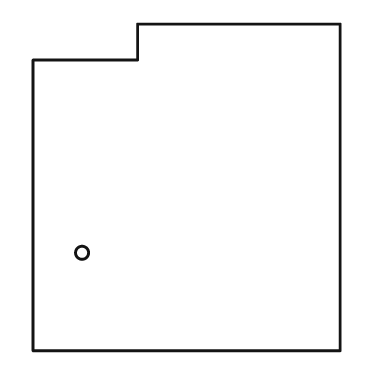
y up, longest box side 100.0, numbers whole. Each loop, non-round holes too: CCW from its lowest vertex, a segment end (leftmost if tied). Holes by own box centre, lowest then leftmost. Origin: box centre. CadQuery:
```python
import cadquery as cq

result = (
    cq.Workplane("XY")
    .moveTo(-47.0, -50.0)
    .lineTo(47.0, -50.0)
    .lineTo(47.0, 50.0)
    .lineTo(-15.0, 50.0)
    .lineTo(-15.0, 39.0)
    .lineTo(-47.0, 39.0)
    .close()
    .moveTo(-32.0, -20.0)
    .circle(2.0)
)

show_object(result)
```